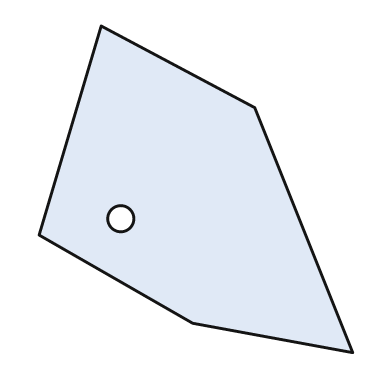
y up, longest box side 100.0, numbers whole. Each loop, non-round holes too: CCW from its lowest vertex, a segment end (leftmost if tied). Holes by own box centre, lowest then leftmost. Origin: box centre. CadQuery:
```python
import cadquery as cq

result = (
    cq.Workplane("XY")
    .moveTo(48.0, -50.0)
    .lineTo(18.0, 25.0)
    .lineTo(-29.0, 50.0)
    .lineTo(-48.0, -14.0)
    .lineTo(-1.0, -41.0)
    .close()
    .moveTo(-23.0, -9.0)
    .circle(4.0)
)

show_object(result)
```